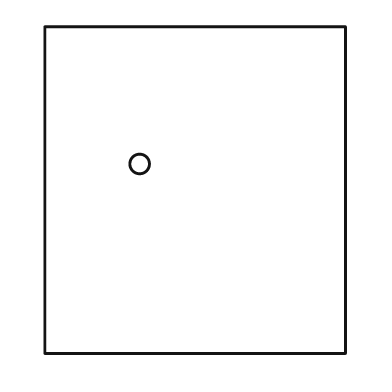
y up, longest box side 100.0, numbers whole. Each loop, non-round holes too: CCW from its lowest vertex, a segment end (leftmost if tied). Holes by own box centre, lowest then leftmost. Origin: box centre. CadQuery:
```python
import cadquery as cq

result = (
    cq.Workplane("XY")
    .moveTo(-46.0, -50.0)
    .lineTo(46.0, -50.0)
    .lineTo(46.0, 50.0)
    .lineTo(-46.0, 50.0)
    .close()
    .moveTo(-17.0, 8.0)
    .circle(3.0)
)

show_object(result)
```